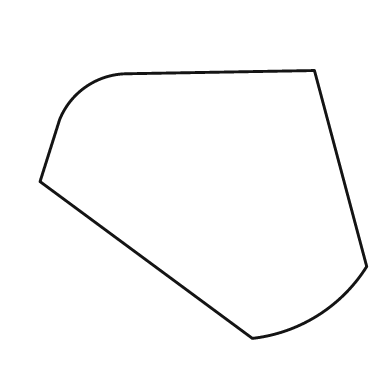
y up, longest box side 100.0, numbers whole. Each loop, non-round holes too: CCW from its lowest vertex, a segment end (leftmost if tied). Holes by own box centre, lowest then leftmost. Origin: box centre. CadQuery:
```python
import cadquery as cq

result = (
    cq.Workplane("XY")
    .moveTo(15.0, -41.0)
    .threePointArc((35.0, -34.0), (50.0, -19.0))
    .lineTo(34.0, 41.0)
    .lineTo(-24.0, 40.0)
    .threePointArc((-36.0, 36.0), (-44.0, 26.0))
    .lineTo(-50.0, 7.0)
    .close()
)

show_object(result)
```